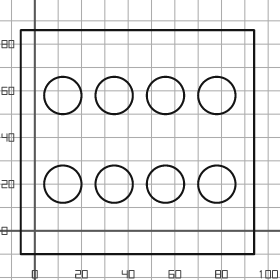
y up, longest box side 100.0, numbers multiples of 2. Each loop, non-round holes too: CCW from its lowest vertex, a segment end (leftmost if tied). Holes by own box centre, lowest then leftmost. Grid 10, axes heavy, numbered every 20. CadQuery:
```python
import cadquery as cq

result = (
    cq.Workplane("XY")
    .moveTo(-6.0, -10.0)
    .lineTo(94.0, -10.0)
    .lineTo(94.0, 86.0)
    .lineTo(-6.0, 86.0)
    .close()
    .moveTo(12.0, 20.0)
    .circle(8.0)
    .moveTo(34.0, 20.0)
    .circle(8.0)
    .moveTo(56.0, 20.0)
    .circle(8.0)
    .moveTo(78.0, 20.0)
    .circle(8.0)
    .moveTo(12.0, 58.0)
    .circle(8.0)
    .moveTo(34.0, 58.0)
    .circle(8.0)
    .moveTo(56.0, 58.0)
    .circle(8.0)
    .moveTo(78.0, 58.0)
    .circle(8.0)
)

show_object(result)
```